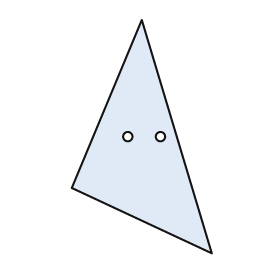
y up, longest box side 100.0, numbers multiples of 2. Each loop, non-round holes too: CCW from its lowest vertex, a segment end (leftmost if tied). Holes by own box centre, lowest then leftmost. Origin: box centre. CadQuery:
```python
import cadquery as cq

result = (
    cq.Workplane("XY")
    .moveTo(30.0, -50.0)
    .lineTo(0.0, 50.0)
    .lineTo(-30.0, -22.0)
    .close()
    .moveTo(-6.0, 0.0)
    .circle(2.0)
    .moveTo(8.0, 0.0)
    .circle(2.0)
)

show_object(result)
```